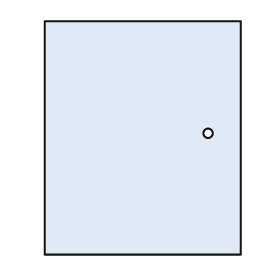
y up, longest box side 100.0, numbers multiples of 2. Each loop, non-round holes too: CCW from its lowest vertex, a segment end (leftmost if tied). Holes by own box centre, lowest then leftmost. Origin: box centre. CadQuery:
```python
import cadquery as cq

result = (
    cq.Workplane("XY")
    .moveTo(-42.0, -50.0)
    .lineTo(42.0, -50.0)
    .lineTo(42.0, 50.0)
    .lineTo(-42.0, 50.0)
    .close()
    .moveTo(28.0, 2.0)
    .circle(2.0)
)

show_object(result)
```